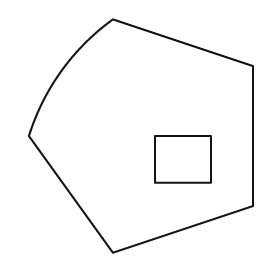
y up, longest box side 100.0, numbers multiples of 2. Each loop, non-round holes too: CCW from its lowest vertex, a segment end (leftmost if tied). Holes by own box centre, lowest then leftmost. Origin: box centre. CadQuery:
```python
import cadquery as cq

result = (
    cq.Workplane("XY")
    .moveTo(-12.0, -50.0)
    .lineTo(48.0, -30.0)
    .lineTo(48.0, 30.0)
    .lineTo(-12.0, 50.0)
    .threePointArc((-34.0, 28.0), (-48.0, 0.0))
    .close()
    .moveTo(6.0, -20.0)
    .lineTo(30.0, -20.0)
    .lineTo(30.0, 0.0)
    .lineTo(6.0, 0.0)
    .close()
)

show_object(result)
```